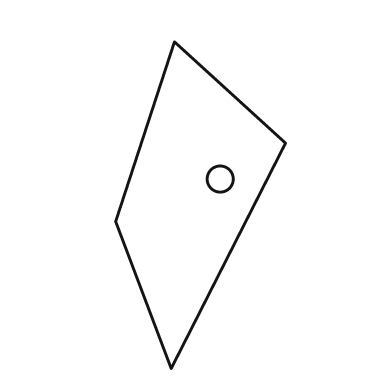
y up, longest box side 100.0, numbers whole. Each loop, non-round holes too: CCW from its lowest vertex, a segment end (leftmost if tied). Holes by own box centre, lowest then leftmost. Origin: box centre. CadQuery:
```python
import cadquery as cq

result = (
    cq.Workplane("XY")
    .moveTo(-9.0, -50.0)
    .lineTo(26.0, 19.0)
    .lineTo(-8.0, 50.0)
    .lineTo(-26.0, -5.0)
    .close()
    .moveTo(6.0, 8.0)
    .circle(4.0)
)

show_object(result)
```